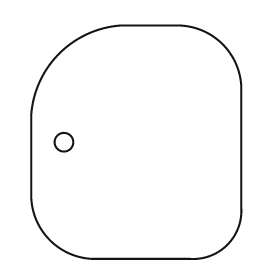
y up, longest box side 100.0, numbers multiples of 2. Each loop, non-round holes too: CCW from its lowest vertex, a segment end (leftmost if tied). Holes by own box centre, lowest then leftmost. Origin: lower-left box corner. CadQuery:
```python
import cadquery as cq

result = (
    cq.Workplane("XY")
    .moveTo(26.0, 0.0)
    .lineTo(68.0, 0.0)
    .threePointArc((84.0, 6.0), (90.0, 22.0))
    .lineTo(90.0, 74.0)
    .threePointArc((82.0, 92.0), (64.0, 100.0))
    .lineTo(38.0, 100.0)
    .threePointArc((12.0, 88.0), (0.0, 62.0))
    .lineTo(0.0, 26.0)
    .threePointArc((8.0, 8.0), (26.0, 0.0))
    .close()
    .moveTo(14.0, 50.0)
    .circle(4.0)
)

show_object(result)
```